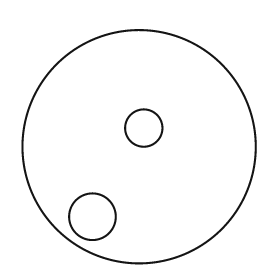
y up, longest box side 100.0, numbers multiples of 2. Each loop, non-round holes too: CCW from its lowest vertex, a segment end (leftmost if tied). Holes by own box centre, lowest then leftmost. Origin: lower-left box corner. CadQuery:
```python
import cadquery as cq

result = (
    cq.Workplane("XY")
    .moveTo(50.0, 50.0)
    .circle(50.0)
    .moveTo(30.0, 20.0)
    .circle(10.0)
    .moveTo(52.0, 58.0)
    .circle(8.0)
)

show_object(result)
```